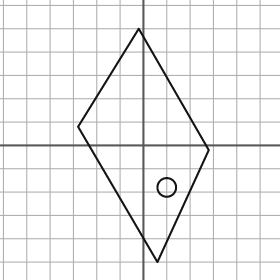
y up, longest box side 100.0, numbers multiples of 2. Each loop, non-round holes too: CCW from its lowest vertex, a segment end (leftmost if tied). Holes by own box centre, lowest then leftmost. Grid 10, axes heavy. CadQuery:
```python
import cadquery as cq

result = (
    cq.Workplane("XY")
    .moveTo(6.0, -50.0)
    .lineTo(28.0, -2.0)
    .lineTo(-2.0, 50.0)
    .lineTo(-28.0, 8.0)
    .close()
    .moveTo(10.0, -18.0)
    .circle(4.0)
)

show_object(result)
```